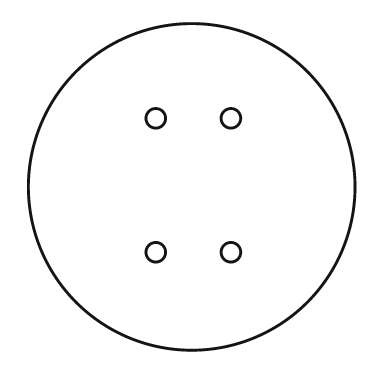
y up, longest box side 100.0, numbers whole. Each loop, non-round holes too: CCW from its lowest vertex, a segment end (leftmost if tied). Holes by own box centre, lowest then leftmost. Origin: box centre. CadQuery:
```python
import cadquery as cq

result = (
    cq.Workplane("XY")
    .moveTo(0.0, 0.0)
    .circle(50.0)
    .moveTo(-11.0, -20.0)
    .circle(3.0)
    .moveTo(12.0, -20.0)
    .circle(3.0)
    .moveTo(-11.0, 21.0)
    .circle(3.0)
    .moveTo(12.0, 21.0)
    .circle(3.0)
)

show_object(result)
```